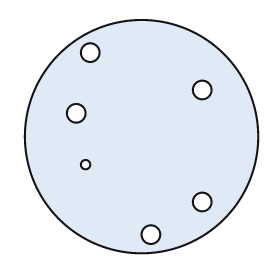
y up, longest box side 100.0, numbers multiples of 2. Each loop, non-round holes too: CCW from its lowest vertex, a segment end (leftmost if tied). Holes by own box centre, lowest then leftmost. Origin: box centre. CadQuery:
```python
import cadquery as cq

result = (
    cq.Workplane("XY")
    .moveTo(0.0, 0.0)
    .circle(50.0)
    .moveTo(4.0, -42.0)
    .circle(4.0)
    .moveTo(26.0, -28.0)
    .circle(4.0)
    .moveTo(-24.0, -12.0)
    .circle(2.0)
    .moveTo(-28.0, 10.0)
    .circle(4.0)
    .moveTo(26.0, 20.0)
    .circle(4.0)
    .moveTo(-22.0, 36.0)
    .circle(4.0)
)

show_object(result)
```